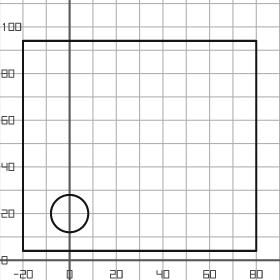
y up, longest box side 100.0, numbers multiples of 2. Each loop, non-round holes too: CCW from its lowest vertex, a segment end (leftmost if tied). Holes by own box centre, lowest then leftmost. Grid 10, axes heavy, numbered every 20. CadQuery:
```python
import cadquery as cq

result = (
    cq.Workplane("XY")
    .moveTo(-20.0, 4.0)
    .lineTo(80.0, 4.0)
    .lineTo(80.0, 94.0)
    .lineTo(-20.0, 94.0)
    .close()
    .moveTo(0.0, 20.0)
    .circle(8.0)
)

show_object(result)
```